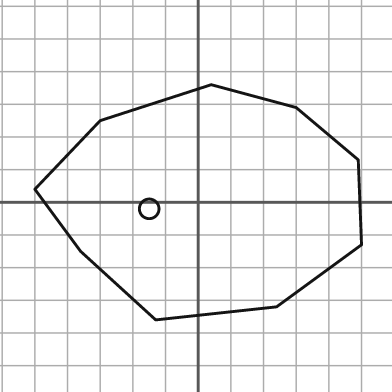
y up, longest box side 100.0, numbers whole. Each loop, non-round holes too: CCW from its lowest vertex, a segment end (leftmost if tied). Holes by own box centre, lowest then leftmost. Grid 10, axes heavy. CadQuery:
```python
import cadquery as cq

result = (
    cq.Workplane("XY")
    .moveTo(-13.0, -36.0)
    .lineTo(24.0, -32.0)
    .lineTo(50.0, -13.0)
    .lineTo(49.0, 13.0)
    .lineTo(30.0, 29.0)
    .lineTo(4.0, 36.0)
    .lineTo(-30.0, 25.0)
    .lineTo(-50.0, 4.0)
    .lineTo(-36.0, -15.0)
    .close()
    .moveTo(-15.0, -2.0)
    .circle(3.0)
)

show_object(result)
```